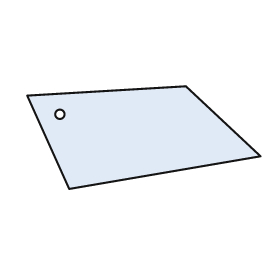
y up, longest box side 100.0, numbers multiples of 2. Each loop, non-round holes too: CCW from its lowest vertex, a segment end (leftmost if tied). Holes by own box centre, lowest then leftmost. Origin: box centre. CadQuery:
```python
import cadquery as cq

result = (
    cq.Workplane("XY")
    .moveTo(-32.0, -22.0)
    .lineTo(50.0, -8.0)
    .lineTo(18.0, 22.0)
    .lineTo(-50.0, 18.0)
    .close()
    .moveTo(-36.0, 10.0)
    .circle(2.0)
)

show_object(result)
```